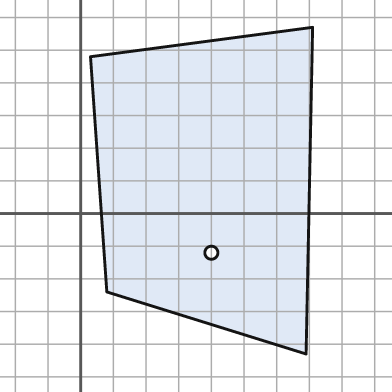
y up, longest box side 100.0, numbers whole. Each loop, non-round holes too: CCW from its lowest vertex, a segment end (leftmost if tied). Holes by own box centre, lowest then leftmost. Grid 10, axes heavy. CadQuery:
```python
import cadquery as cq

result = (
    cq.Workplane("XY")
    .moveTo(69.0, -43.0)
    .lineTo(71.0, 57.0)
    .lineTo(3.0, 48.0)
    .lineTo(8.0, -24.0)
    .close()
    .moveTo(40.0, -12.0)
    .circle(2.0)
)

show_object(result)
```